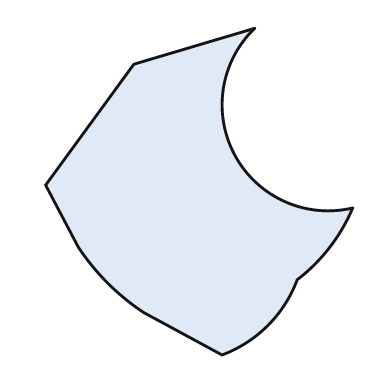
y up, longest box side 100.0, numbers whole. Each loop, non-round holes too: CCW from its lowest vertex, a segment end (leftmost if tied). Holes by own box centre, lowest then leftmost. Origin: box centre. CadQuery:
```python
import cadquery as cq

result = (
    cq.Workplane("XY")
    .moveTo(7.0, -50.0)
    .threePointArc((21.0, -41.0), (30.0, -27.0))
    .threePointArc((40.0, -17.0), (47.0, -5.0))
    .threePointArc((11.0, 11.0), (17.0, 50.0))
    .lineTo(-20.0, 39.0)
    .lineTo(-47.0, 2.0)
    .lineTo(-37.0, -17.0)
    .threePointArc((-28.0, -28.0), (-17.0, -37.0))
    .close()
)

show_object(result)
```